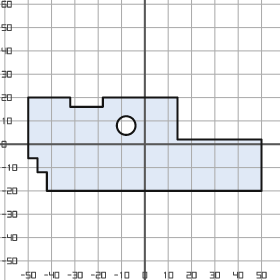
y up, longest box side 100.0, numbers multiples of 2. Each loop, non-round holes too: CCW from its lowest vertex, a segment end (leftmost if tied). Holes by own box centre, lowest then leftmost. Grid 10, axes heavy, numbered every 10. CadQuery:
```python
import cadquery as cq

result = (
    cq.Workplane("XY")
    .moveTo(-42.0, -20.0)
    .lineTo(50.0, -20.0)
    .lineTo(50.0, 2.0)
    .lineTo(14.0, 2.0)
    .lineTo(14.0, 20.0)
    .lineTo(-18.0, 20.0)
    .lineTo(-18.0, 16.0)
    .lineTo(-32.0, 16.0)
    .lineTo(-32.0, 20.0)
    .lineTo(-50.0, 20.0)
    .lineTo(-50.0, -6.0)
    .lineTo(-46.0, -6.0)
    .lineTo(-46.0, -12.0)
    .lineTo(-42.0, -12.0)
    .close()
    .moveTo(-8.0, 8.0)
    .circle(4.0)
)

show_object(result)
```